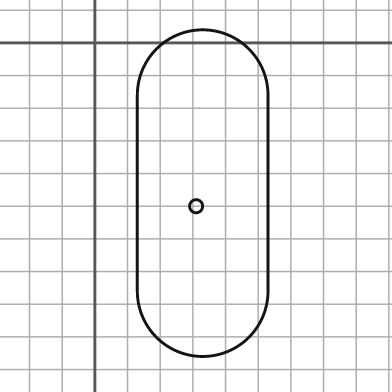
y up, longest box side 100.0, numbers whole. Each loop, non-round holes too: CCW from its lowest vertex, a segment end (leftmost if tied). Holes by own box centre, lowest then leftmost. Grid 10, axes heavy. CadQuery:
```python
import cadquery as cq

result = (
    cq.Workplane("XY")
    .moveTo(13.0, -76.0)
    .threePointArc((33.0, -96.0), (53.0, -76.0))
    .lineTo(53.0, -16.0)
    .threePointArc((33.0, 4.0), (13.0, -16.0))
    .close()
    .moveTo(31.0, -50.0)
    .circle(2.0)
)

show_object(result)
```